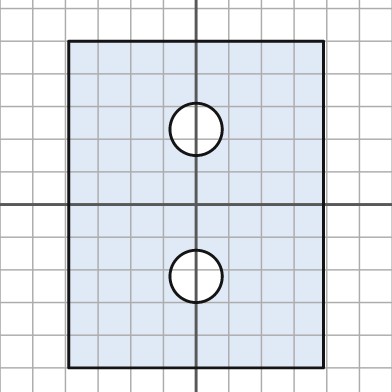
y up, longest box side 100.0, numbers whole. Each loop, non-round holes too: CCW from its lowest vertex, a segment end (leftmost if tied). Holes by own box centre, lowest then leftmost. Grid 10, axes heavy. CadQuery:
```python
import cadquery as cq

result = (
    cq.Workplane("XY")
    .moveTo(-39.0, -50.0)
    .lineTo(39.0, -50.0)
    .lineTo(39.0, 50.0)
    .lineTo(-39.0, 50.0)
    .close()
    .moveTo(0.0, -22.0)
    .circle(8.0)
    .moveTo(0.0, 23.0)
    .circle(8.0)
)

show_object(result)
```